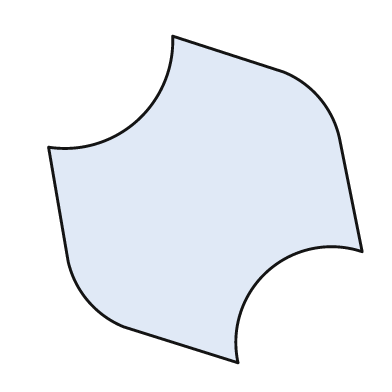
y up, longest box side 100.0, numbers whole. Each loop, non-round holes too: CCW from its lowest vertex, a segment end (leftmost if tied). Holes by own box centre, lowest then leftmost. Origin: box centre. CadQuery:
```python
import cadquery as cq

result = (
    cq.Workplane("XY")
    .moveTo(10.0, -50.0)
    .threePointArc((19.0, -22.0), (48.0, -16.0))
    .lineTo(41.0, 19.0)
    .threePointArc((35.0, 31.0), (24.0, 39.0))
    .lineTo(-10.0, 50.0)
    .threePointArc((-21.0, 24.0), (-48.0, 16.0))
    .lineTo(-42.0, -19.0)
    .threePointArc((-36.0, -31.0), (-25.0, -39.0))
    .close()
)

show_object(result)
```